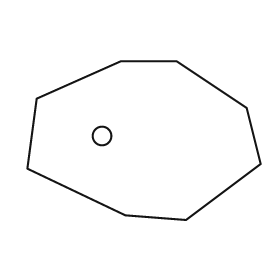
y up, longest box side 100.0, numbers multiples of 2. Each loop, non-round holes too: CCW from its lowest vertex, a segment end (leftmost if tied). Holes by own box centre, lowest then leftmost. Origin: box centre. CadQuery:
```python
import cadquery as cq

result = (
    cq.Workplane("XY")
    .moveTo(18.0, -34.0)
    .lineTo(50.0, -10.0)
    .lineTo(44.0, 14.0)
    .lineTo(14.0, 34.0)
    .lineTo(-10.0, 34.0)
    .lineTo(-46.0, 18.0)
    .lineTo(-50.0, -12.0)
    .lineTo(-8.0, -32.0)
    .close()
    .moveTo(-18.0, 2.0)
    .circle(4.0)
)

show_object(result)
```